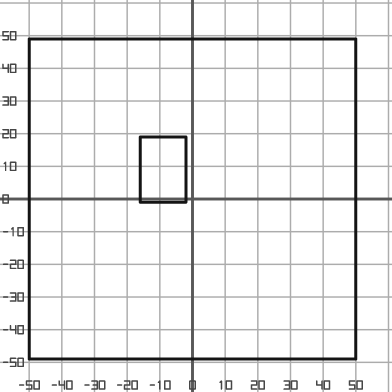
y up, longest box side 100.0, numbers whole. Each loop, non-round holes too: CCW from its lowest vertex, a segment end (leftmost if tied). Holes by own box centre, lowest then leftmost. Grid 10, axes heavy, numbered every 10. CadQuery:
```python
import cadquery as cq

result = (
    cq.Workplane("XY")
    .moveTo(-50.0, -49.0)
    .lineTo(50.0, -49.0)
    .lineTo(50.0, 49.0)
    .lineTo(-50.0, 49.0)
    .close()
    .moveTo(-16.0, -1.0)
    .lineTo(-2.0, -1.0)
    .lineTo(-2.0, 19.0)
    .lineTo(-16.0, 19.0)
    .close()
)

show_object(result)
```